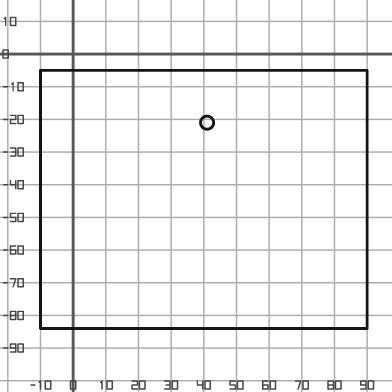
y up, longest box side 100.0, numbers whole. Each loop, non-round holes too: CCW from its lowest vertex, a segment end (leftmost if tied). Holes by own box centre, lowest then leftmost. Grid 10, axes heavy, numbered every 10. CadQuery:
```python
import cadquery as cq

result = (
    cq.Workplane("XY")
    .moveTo(-10.0, -84.0)
    .lineTo(90.0, -84.0)
    .lineTo(90.0, -5.0)
    .lineTo(-10.0, -5.0)
    .close()
    .moveTo(41.0, -21.0)
    .circle(2.0)
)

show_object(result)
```